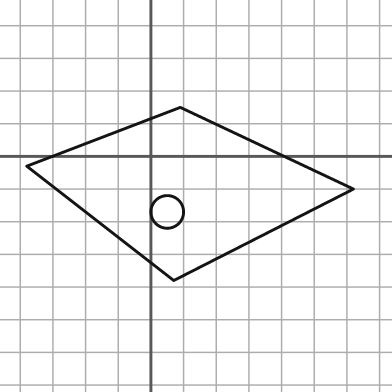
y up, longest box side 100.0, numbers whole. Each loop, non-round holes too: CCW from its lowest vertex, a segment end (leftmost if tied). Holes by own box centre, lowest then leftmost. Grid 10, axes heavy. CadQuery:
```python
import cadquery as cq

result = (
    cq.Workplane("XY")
    .moveTo(7.0, -38.0)
    .lineTo(62.0, -10.0)
    .lineTo(9.0, 15.0)
    .lineTo(-38.0, -3.0)
    .close()
    .moveTo(5.0, -17.0)
    .circle(5.0)
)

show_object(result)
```